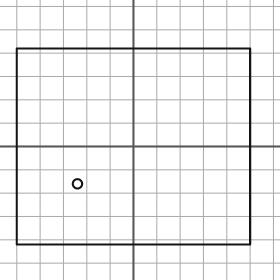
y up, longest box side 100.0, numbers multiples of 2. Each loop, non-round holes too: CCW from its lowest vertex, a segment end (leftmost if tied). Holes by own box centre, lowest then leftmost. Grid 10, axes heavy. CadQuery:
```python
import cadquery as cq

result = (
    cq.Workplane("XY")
    .moveTo(-50.0, -42.0)
    .lineTo(50.0, -42.0)
    .lineTo(50.0, 42.0)
    .lineTo(-50.0, 42.0)
    .close()
    .moveTo(-24.0, -16.0)
    .circle(2.0)
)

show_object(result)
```